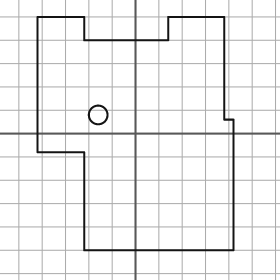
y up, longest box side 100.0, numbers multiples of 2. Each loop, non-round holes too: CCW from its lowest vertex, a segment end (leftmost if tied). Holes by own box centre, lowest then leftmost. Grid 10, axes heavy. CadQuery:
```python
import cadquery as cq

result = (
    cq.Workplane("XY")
    .moveTo(-22.0, -50.0)
    .lineTo(42.0, -50.0)
    .lineTo(42.0, 6.0)
    .lineTo(38.0, 6.0)
    .lineTo(38.0, 50.0)
    .lineTo(14.0, 50.0)
    .lineTo(14.0, 40.0)
    .lineTo(-22.0, 40.0)
    .lineTo(-22.0, 50.0)
    .lineTo(-42.0, 50.0)
    .lineTo(-42.0, -8.0)
    .lineTo(-22.0, -8.0)
    .close()
    .moveTo(-16.0, 8.0)
    .circle(4.0)
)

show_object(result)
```